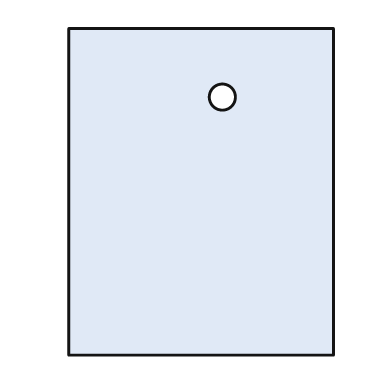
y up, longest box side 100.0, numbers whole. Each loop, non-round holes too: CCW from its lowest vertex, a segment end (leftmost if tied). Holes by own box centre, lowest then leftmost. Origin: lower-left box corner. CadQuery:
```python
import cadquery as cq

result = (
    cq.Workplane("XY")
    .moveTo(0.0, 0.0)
    .lineTo(81.0, 0.0)
    .lineTo(81.0, 100.0)
    .lineTo(0.0, 100.0)
    .close()
    .moveTo(47.0, 79.0)
    .circle(4.0)
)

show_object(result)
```